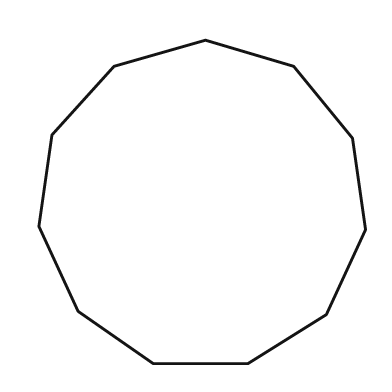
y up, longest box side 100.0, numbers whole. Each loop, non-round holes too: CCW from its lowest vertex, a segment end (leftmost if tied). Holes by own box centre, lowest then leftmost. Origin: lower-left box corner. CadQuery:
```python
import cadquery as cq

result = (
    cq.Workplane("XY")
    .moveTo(35.0, 0.0)
    .lineTo(64.0, 0.0)
    .lineTo(88.0, 15.0)
    .lineTo(100.0, 41.0)
    .lineTo(96.0, 69.0)
    .lineTo(78.0, 91.0)
    .lineTo(51.0, 99.0)
    .lineTo(23.0, 91.0)
    .lineTo(4.0, 70.0)
    .lineTo(0.0, 42.0)
    .lineTo(12.0, 16.0)
    .close()
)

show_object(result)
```